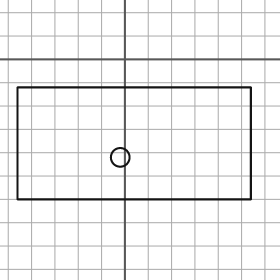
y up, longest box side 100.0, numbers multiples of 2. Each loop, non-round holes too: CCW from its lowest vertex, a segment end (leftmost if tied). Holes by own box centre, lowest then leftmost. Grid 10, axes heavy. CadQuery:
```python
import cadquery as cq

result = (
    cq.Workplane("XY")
    .moveTo(-46.0, -60.0)
    .lineTo(54.0, -60.0)
    .lineTo(54.0, -12.0)
    .lineTo(-46.0, -12.0)
    .close()
    .moveTo(-2.0, -42.0)
    .circle(4.0)
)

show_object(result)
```